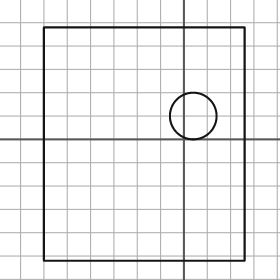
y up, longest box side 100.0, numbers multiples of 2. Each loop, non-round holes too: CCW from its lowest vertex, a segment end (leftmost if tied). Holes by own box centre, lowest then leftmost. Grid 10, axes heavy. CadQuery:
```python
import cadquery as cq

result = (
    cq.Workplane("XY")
    .moveTo(-60.0, -52.0)
    .lineTo(26.0, -52.0)
    .lineTo(26.0, 48.0)
    .lineTo(-60.0, 48.0)
    .close()
    .moveTo(4.0, 10.0)
    .circle(10.0)
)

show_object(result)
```